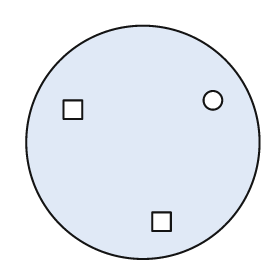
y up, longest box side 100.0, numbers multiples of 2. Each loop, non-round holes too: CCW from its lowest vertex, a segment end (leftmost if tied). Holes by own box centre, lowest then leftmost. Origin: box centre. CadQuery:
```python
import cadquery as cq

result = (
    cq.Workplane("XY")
    .moveTo(0.0, 0.0)
    .circle(50.0)
    .moveTo(4.0, -38.0)
    .lineTo(12.0, -38.0)
    .lineTo(12.0, -30.0)
    .lineTo(4.0, -30.0)
    .close()
    .moveTo(-34.0, 10.0)
    .lineTo(-26.0, 10.0)
    .lineTo(-26.0, 18.0)
    .lineTo(-34.0, 18.0)
    .close()
    .moveTo(30.0, 18.0)
    .circle(4.0)
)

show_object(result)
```